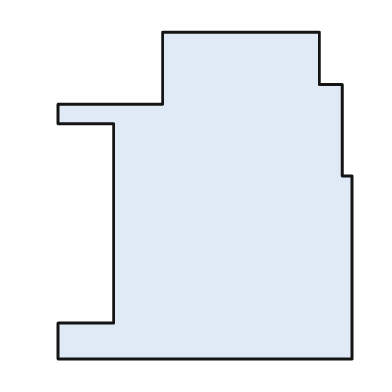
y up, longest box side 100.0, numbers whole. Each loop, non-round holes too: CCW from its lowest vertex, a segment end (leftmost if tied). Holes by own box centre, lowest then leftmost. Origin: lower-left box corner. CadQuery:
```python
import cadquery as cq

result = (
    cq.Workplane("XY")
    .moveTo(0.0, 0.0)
    .lineTo(90.0, 0.0)
    .lineTo(90.0, 56.0)
    .lineTo(87.0, 56.0)
    .lineTo(87.0, 84.0)
    .lineTo(80.0, 84.0)
    .lineTo(80.0, 100.0)
    .lineTo(32.0, 100.0)
    .lineTo(32.0, 78.0)
    .lineTo(0.0, 78.0)
    .lineTo(0.0, 72.0)
    .lineTo(17.0, 72.0)
    .lineTo(17.0, 11.0)
    .lineTo(0.0, 11.0)
    .close()
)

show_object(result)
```